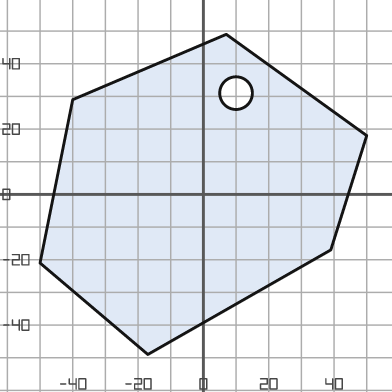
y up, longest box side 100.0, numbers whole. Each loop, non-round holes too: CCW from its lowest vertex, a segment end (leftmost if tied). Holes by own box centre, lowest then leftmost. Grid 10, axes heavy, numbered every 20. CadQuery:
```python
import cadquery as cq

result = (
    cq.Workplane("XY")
    .moveTo(-17.0, -49.0)
    .lineTo(39.0, -17.0)
    .lineTo(50.0, 18.0)
    .lineTo(7.0, 49.0)
    .lineTo(-40.0, 29.0)
    .lineTo(-50.0, -21.0)
    .close()
    .moveTo(10.0, 31.0)
    .circle(5.0)
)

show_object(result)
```